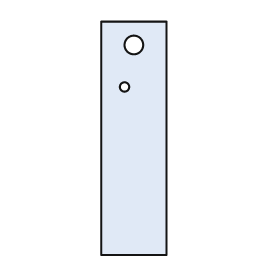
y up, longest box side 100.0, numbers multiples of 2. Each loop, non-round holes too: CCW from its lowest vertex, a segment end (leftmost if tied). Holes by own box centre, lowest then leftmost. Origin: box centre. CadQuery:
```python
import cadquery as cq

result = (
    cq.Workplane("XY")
    .moveTo(-14.0, -50.0)
    .lineTo(14.0, -50.0)
    .lineTo(14.0, 50.0)
    .lineTo(-14.0, 50.0)
    .close()
    .moveTo(-4.0, 22.0)
    .circle(2.0)
    .moveTo(0.0, 40.0)
    .circle(4.0)
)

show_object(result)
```